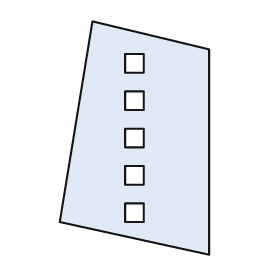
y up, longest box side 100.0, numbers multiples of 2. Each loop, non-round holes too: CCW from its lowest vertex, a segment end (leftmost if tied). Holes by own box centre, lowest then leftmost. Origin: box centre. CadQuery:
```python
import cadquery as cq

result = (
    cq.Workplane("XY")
    .moveTo(32.0, -50.0)
    .lineTo(32.0, 38.0)
    .lineTo(-18.0, 50.0)
    .lineTo(-32.0, -36.0)
    .close()
    .moveTo(-4.0, -36.0)
    .lineTo(4.0, -36.0)
    .lineTo(4.0, -28.0)
    .lineTo(-4.0, -28.0)
    .close()
    .moveTo(-4.0, -20.0)
    .lineTo(4.0, -20.0)
    .lineTo(4.0, -12.0)
    .lineTo(-4.0, -12.0)
    .close()
    .moveTo(-4.0, -4.0)
    .lineTo(4.0, -4.0)
    .lineTo(4.0, 4.0)
    .lineTo(-4.0, 4.0)
    .close()
    .moveTo(-4.0, 12.0)
    .lineTo(4.0, 12.0)
    .lineTo(4.0, 20.0)
    .lineTo(-4.0, 20.0)
    .close()
    .moveTo(-4.0, 28.0)
    .lineTo(4.0, 28.0)
    .lineTo(4.0, 36.0)
    .lineTo(-4.0, 36.0)
    .close()
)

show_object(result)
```